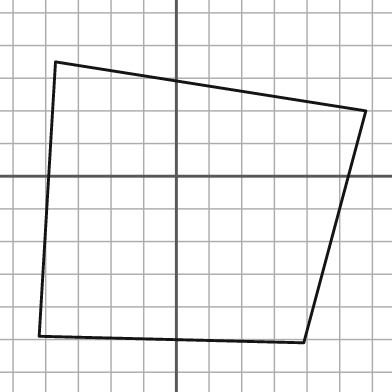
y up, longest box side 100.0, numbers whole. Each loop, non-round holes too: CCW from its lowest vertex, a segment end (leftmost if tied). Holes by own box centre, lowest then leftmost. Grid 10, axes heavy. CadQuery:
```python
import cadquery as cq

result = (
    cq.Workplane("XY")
    .moveTo(39.0, -51.0)
    .lineTo(58.0, 20.0)
    .lineTo(-37.0, 35.0)
    .lineTo(-42.0, -49.0)
    .close()
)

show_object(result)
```